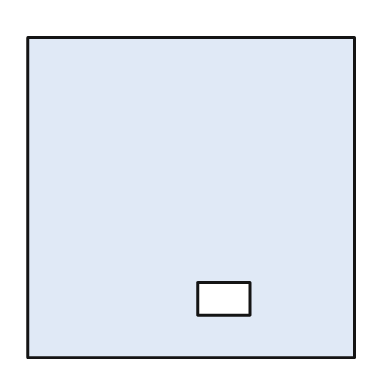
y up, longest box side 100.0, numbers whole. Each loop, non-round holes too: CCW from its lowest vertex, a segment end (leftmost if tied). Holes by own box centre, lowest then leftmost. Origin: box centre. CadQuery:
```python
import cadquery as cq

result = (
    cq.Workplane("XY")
    .moveTo(-50.0, -49.0)
    .lineTo(50.0, -49.0)
    .lineTo(50.0, 49.0)
    .lineTo(-50.0, 49.0)
    .close()
    .moveTo(2.0, -36.0)
    .lineTo(18.0, -36.0)
    .lineTo(18.0, -26.0)
    .lineTo(2.0, -26.0)
    .close()
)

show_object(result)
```